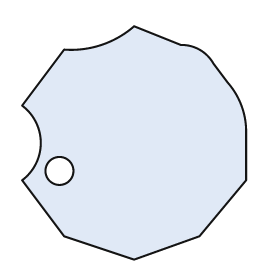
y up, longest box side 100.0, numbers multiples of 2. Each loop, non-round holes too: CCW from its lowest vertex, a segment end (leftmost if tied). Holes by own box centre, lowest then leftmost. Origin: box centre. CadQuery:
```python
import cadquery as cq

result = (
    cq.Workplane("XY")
    .moveTo(0.0, -50.0)
    .lineTo(28.0, -40.0)
    .lineTo(48.0, -16.0)
    .lineTo(48.0, 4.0)
    .threePointArc((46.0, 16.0), (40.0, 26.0))
    .lineTo(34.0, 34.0)
    .threePointArc((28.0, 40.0), (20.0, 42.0))
    .lineTo(0.0, 50.0)
    .threePointArc((-14.0, 42.0), (-30.0, 40.0))
    .lineTo(-48.0, 16.0)
    .threePointArc((-40.0, 0.0), (-48.0, -16.0))
    .lineTo(-30.0, -40.0)
    .close()
    .moveTo(-32.0, -12.0)
    .circle(6.0)
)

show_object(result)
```